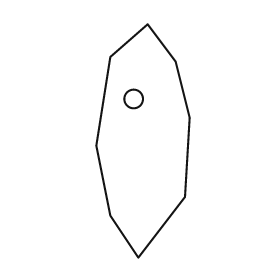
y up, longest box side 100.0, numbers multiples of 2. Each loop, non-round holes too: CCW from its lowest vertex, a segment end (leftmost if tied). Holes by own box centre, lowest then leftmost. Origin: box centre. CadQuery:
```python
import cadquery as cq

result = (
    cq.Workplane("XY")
    .moveTo(-2.0, -50.0)
    .lineTo(18.0, -24.0)
    .lineTo(20.0, 10.0)
    .lineTo(14.0, 34.0)
    .lineTo(2.0, 50.0)
    .lineTo(-14.0, 36.0)
    .lineTo(-20.0, -2.0)
    .lineTo(-14.0, -32.0)
    .close()
    .moveTo(-4.0, 18.0)
    .circle(4.0)
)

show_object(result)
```